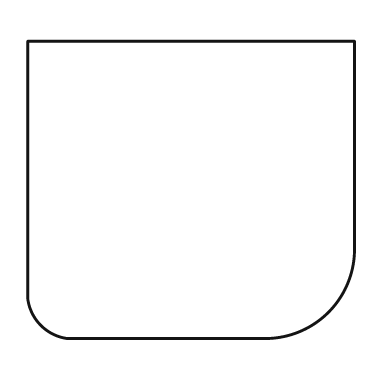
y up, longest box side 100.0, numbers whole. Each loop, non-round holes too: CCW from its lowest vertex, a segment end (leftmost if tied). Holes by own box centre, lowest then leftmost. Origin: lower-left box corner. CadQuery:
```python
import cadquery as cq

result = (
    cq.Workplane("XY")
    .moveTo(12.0, 0.0)
    .lineTo(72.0, 0.0)
    .threePointArc((92.0, 8.0), (100.0, 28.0))
    .lineTo(100.0, 91.0)
    .lineTo(0.0, 91.0)
    .lineTo(0.0, 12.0)
    .threePointArc((4.0, 4.0), (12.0, 0.0))
    .close()
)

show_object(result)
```